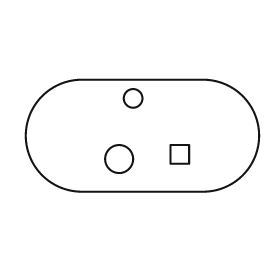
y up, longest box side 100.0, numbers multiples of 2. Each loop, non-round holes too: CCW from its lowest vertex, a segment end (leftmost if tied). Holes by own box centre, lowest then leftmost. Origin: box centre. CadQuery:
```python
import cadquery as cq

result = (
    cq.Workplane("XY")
    .moveTo(-26.0, -24.0)
    .lineTo(26.0, -24.0)
    .threePointArc((50.0, 0.0), (26.0, 24.0))
    .lineTo(-26.0, 24.0)
    .threePointArc((-50.0, 0.0), (-26.0, -24.0))
    .close()
    .moveTo(-10.0, -10.0)
    .circle(6.0)
    .moveTo(12.0, -12.0)
    .lineTo(20.0, -12.0)
    .lineTo(20.0, -4.0)
    .lineTo(12.0, -4.0)
    .close()
    .moveTo(-4.0, 16.0)
    .circle(4.0)
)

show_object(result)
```